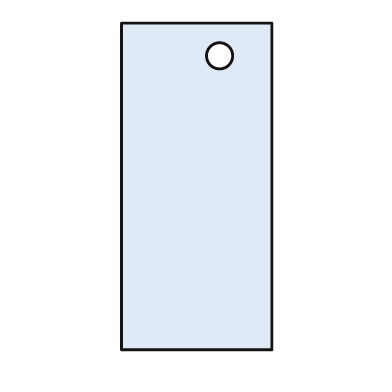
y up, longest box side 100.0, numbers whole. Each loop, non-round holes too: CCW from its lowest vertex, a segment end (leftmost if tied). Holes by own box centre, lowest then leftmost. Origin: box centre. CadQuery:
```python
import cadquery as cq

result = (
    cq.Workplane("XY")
    .moveTo(-23.0, -50.0)
    .lineTo(23.0, -50.0)
    .lineTo(23.0, 50.0)
    .lineTo(-23.0, 50.0)
    .close()
    .moveTo(7.0, 40.0)
    .circle(4.0)
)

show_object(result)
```